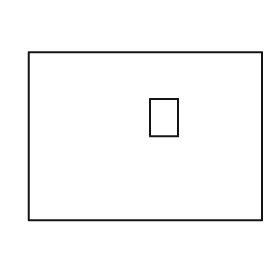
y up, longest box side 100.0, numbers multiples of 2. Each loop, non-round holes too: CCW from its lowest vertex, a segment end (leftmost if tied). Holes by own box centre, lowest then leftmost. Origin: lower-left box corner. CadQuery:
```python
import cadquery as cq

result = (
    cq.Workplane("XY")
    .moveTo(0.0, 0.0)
    .lineTo(100.0, 0.0)
    .lineTo(100.0, 72.0)
    .lineTo(0.0, 72.0)
    .close()
    .moveTo(52.0, 36.0)
    .lineTo(64.0, 36.0)
    .lineTo(64.0, 52.0)
    .lineTo(52.0, 52.0)
    .close()
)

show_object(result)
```